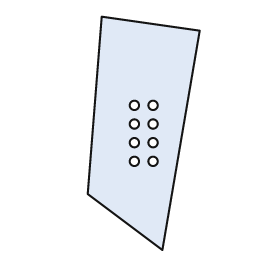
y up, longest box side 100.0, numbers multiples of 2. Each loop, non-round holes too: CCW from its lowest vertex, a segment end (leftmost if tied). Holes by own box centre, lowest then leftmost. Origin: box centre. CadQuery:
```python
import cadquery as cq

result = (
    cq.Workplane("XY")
    .moveTo(8.0, -50.0)
    .lineTo(24.0, 44.0)
    .lineTo(-18.0, 50.0)
    .lineTo(-24.0, -26.0)
    .close()
    .moveTo(-4.0, -12.0)
    .circle(2.0)
    .moveTo(4.0, -12.0)
    .circle(2.0)
    .moveTo(-4.0, -4.0)
    .circle(2.0)
    .moveTo(4.0, -4.0)
    .circle(2.0)
    .moveTo(-4.0, 4.0)
    .circle(2.0)
    .moveTo(4.0, 4.0)
    .circle(2.0)
    .moveTo(-4.0, 12.0)
    .circle(2.0)
    .moveTo(4.0, 12.0)
    .circle(2.0)
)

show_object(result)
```